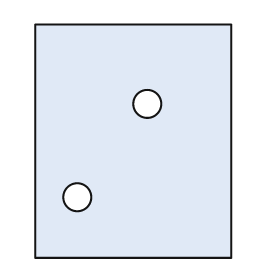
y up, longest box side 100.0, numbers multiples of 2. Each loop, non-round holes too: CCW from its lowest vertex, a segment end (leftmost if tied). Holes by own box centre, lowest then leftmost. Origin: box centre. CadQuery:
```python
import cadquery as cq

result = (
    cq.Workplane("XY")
    .moveTo(-42.0, -50.0)
    .lineTo(42.0, -50.0)
    .lineTo(42.0, 50.0)
    .lineTo(-42.0, 50.0)
    .close()
    .moveTo(-24.0, -24.0)
    .circle(6.0)
    .moveTo(6.0, 16.0)
    .circle(6.0)
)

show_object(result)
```